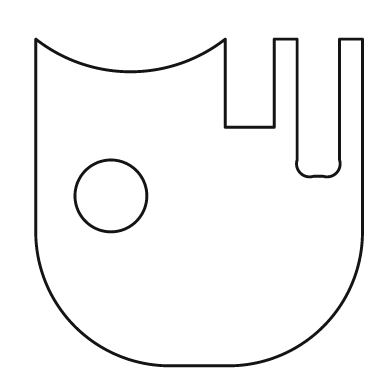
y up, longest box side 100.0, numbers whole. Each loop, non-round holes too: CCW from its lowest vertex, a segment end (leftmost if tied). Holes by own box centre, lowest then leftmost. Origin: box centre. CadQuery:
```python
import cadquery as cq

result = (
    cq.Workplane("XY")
    .moveTo(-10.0, -50.0)
    .lineTo(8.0, -50.0)
    .threePointArc((38.0, -38.0), (50.0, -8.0))
    .lineTo(50.0, 50.0)
    .lineTo(43.0, 50.0)
    .lineTo(43.0, 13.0)
    .threePointArc((42.0, 9.0), (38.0, 8.0))
    .lineTo(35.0, 8.0)
    .threePointArc((31.0, 9.0), (30.0, 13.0))
    .lineTo(30.0, 50.0)
    .lineTo(23.0, 50.0)
    .lineTo(23.0, 23.0)
    .lineTo(8.0, 23.0)
    .lineTo(8.0, 50.0)
    .threePointArc((-21.0, 40.0), (-50.0, 50.0))
    .lineTo(-50.0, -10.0)
    .threePointArc((-38.0, -38.0), (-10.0, -50.0))
    .close()
    .moveTo(-27.0, 2.0)
    .circle(11.0)
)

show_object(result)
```